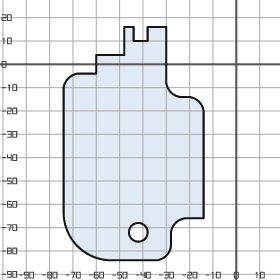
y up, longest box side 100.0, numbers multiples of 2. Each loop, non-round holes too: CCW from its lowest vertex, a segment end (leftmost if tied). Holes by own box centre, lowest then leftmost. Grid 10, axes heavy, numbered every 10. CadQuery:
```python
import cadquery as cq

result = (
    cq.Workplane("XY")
    .moveTo(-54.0, -84.0)
    .lineTo(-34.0, -84.0)
    .threePointArc((-30.0, -82.0), (-28.0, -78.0))
    .lineTo(-28.0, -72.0)
    .threePointArc((-26.0, -68.0), (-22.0, -66.0))
    .lineTo(-14.0, -66.0)
    .lineTo(-14.0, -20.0)
    .threePointArc((-16.0, -16.0), (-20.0, -14.0))
    .lineTo(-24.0, -14.0)
    .threePointArc((-28.0, -12.0), (-30.0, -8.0))
    .lineTo(-30.0, 16.0)
    .lineTo(-38.0, 16.0)
    .lineTo(-38.0, 10.0)
    .lineTo(-44.0, 10.0)
    .lineTo(-44.0, 16.0)
    .lineTo(-48.0, 16.0)
    .lineTo(-48.0, 4.0)
    .lineTo(-60.0, 4.0)
    .lineTo(-60.0, -4.0)
    .lineTo(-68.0, -4.0)
    .threePointArc((-72.0, -6.0), (-74.0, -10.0))
    .lineTo(-74.0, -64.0)
    .threePointArc((-68.0, -78.0), (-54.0, -84.0))
    .close()
    .moveTo(-42.0, -72.0)
    .circle(4.0)
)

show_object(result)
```